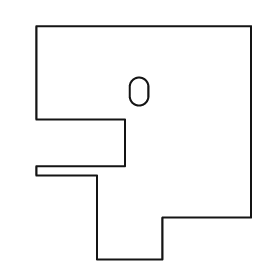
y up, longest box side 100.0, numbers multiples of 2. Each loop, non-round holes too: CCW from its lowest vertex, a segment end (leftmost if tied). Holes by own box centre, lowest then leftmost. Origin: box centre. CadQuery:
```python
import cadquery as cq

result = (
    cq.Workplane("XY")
    .moveTo(-20.0, -50.0)
    .lineTo(8.0, -50.0)
    .lineTo(8.0, -32.0)
    .lineTo(46.0, -32.0)
    .lineTo(46.0, 50.0)
    .lineTo(-46.0, 50.0)
    .lineTo(-46.0, 10.0)
    .lineTo(-8.0, 10.0)
    .lineTo(-8.0, -10.0)
    .lineTo(-46.0, -10.0)
    .lineTo(-46.0, -14.0)
    .lineTo(-20.0, -14.0)
    .close()
    .moveTo(-6.0, 20.0)
    .threePointArc((-2.0, 16.0), (2.0, 20.0))
    .lineTo(2.0, 24.0)
    .threePointArc((-2.0, 28.0), (-6.0, 24.0))
    .close()
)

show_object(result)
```